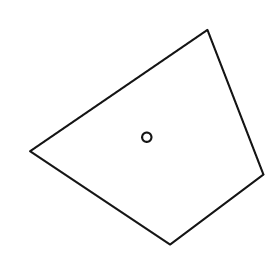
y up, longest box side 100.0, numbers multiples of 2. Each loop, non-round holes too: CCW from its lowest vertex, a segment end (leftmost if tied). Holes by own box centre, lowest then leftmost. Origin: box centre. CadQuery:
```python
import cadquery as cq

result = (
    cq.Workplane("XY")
    .moveTo(10.0, -46.0)
    .lineTo(50.0, -16.0)
    .lineTo(26.0, 46.0)
    .lineTo(-50.0, -6.0)
    .close()
    .moveTo(0.0, 0.0)
    .circle(2.0)
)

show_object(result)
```